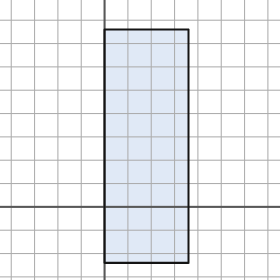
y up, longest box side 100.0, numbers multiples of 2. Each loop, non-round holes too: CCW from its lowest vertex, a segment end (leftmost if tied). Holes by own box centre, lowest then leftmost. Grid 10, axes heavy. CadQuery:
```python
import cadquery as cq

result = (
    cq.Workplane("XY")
    .moveTo(0.0, -24.0)
    .lineTo(36.0, -24.0)
    .lineTo(36.0, 76.0)
    .lineTo(0.0, 76.0)
    .close()
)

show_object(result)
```